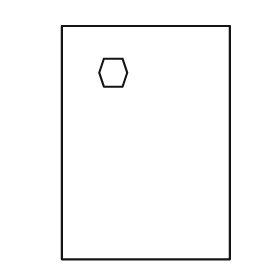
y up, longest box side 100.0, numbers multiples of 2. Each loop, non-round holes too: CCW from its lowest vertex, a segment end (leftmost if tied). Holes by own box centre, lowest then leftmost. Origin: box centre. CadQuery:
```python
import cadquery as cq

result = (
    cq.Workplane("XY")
    .moveTo(-36.0, -50.0)
    .lineTo(36.0, -50.0)
    .lineTo(36.0, 50.0)
    .lineTo(-36.0, 50.0)
    .close()
    .moveTo(-18.0, 24.0)
    .lineTo(-10.0, 24.0)
    .lineTo(-8.0, 30.0)
    .lineTo(-10.0, 36.0)
    .lineTo(-18.0, 36.0)
    .lineTo(-20.0, 30.0)
    .close()
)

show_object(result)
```